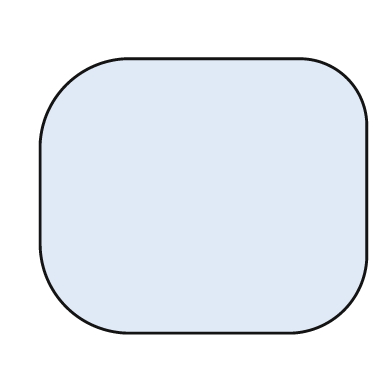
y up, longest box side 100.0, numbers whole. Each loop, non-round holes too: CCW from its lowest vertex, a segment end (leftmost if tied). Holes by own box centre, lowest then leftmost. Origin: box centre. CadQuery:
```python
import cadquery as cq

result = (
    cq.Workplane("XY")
    .moveTo(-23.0, -42.0)
    .lineTo(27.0, -42.0)
    .threePointArc((43.0, -35.0), (50.0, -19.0))
    .lineTo(50.0, 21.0)
    .threePointArc((44.0, 36.0), (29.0, 42.0))
    .lineTo(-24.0, 42.0)
    .threePointArc((-42.0, 34.0), (-50.0, 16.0))
    .lineTo(-50.0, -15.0)
    .threePointArc((-42.0, -34.0), (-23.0, -42.0))
    .close()
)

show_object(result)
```